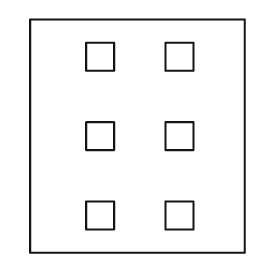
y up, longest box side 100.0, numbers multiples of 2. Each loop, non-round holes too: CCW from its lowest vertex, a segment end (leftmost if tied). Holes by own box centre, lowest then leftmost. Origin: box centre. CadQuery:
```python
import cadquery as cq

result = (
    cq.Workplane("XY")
    .moveTo(-46.0, -50.0)
    .lineTo(46.0, -50.0)
    .lineTo(46.0, 50.0)
    .lineTo(-46.0, 50.0)
    .close()
    .moveTo(-22.0, -40.0)
    .lineTo(-10.0, -40.0)
    .lineTo(-10.0, -28.0)
    .lineTo(-22.0, -28.0)
    .close()
    .moveTo(12.0, -40.0)
    .lineTo(24.0, -40.0)
    .lineTo(24.0, -28.0)
    .lineTo(12.0, -28.0)
    .close()
    .moveTo(-22.0, -6.0)
    .lineTo(-10.0, -6.0)
    .lineTo(-10.0, 6.0)
    .lineTo(-22.0, 6.0)
    .close()
    .moveTo(12.0, -6.0)
    .lineTo(24.0, -6.0)
    .lineTo(24.0, 6.0)
    .lineTo(12.0, 6.0)
    .close()
    .moveTo(-22.0, 28.0)
    .lineTo(-10.0, 28.0)
    .lineTo(-10.0, 40.0)
    .lineTo(-22.0, 40.0)
    .close()
    .moveTo(12.0, 28.0)
    .lineTo(24.0, 28.0)
    .lineTo(24.0, 40.0)
    .lineTo(12.0, 40.0)
    .close()
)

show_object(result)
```